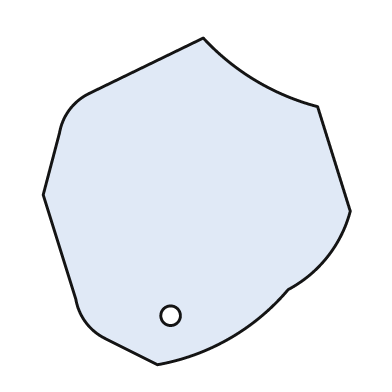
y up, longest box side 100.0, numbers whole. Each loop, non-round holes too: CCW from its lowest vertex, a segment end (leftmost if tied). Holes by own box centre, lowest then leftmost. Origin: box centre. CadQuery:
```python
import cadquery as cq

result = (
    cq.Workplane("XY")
    .moveTo(-12.0, -50.0)
    .threePointArc((10.0, -42.0), (28.0, -27.0))
    .threePointArc((40.0, -17.0), (47.0, -3.0))
    .lineTo(37.0, 29.0)
    .threePointArc((18.0, 37.0), (2.0, 50.0))
    .lineTo(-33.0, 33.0)
    .threePointArc((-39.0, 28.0), (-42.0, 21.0))
    .lineTo(-47.0, 2.0)
    .lineTo(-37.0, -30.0)
    .threePointArc((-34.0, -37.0), (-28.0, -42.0))
    .close()
    .moveTo(-8.0, -35.0)
    .circle(3.0)
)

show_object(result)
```